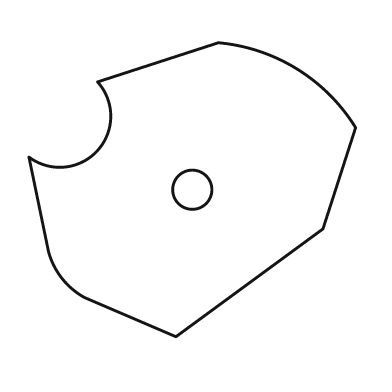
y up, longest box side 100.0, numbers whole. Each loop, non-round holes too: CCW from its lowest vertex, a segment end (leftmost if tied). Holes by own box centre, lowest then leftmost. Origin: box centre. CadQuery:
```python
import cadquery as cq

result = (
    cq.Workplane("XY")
    .moveTo(-5.0, -45.0)
    .lineTo(40.0, -12.0)
    .lineTo(50.0, 19.0)
    .threePointArc((32.0, 37.0), (8.0, 45.0))
    .lineTo(-29.0, 33.0)
    .threePointArc((-29.0, 12.0), (-50.0, 10.0))
    .lineTo(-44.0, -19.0)
    .threePointArc((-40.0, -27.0), (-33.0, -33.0))
    .close()
    .moveTo(0.0, 0.0)
    .circle(6.0)
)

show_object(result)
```